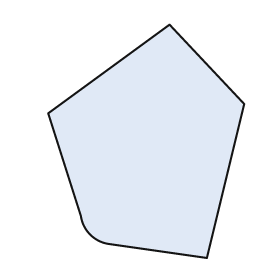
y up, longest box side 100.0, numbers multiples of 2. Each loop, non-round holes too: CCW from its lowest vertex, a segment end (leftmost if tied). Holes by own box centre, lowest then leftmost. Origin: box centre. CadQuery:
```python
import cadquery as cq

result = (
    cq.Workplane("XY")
    .moveTo(26.0, -50.0)
    .lineTo(42.0, 16.0)
    .lineTo(10.0, 50.0)
    .lineTo(-42.0, 12.0)
    .lineTo(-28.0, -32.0)
    .threePointArc((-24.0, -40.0), (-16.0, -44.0))
    .close()
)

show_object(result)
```